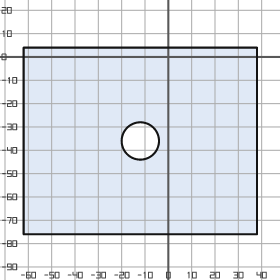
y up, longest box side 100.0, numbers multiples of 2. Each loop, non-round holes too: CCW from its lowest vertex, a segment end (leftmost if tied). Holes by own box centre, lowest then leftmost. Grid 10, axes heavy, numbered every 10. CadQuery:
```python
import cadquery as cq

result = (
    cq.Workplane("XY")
    .moveTo(-62.0, -76.0)
    .lineTo(38.0, -76.0)
    .lineTo(38.0, 4.0)
    .lineTo(-62.0, 4.0)
    .close()
    .moveTo(-12.0, -36.0)
    .circle(8.0)
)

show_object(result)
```